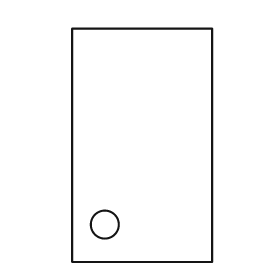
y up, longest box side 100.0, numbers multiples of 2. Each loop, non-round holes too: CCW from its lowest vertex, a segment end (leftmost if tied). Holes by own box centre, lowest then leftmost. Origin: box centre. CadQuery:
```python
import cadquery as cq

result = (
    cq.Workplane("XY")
    .moveTo(-30.0, -50.0)
    .lineTo(30.0, -50.0)
    .lineTo(30.0, 50.0)
    .lineTo(-30.0, 50.0)
    .close()
    .moveTo(-16.0, -34.0)
    .circle(6.0)
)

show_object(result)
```